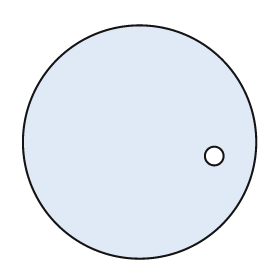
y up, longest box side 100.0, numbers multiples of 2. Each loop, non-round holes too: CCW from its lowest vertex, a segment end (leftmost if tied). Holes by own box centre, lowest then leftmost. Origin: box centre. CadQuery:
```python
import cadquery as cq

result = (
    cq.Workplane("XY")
    .moveTo(0.0, 0.0)
    .circle(50.0)
    .moveTo(32.0, -6.0)
    .circle(4.0)
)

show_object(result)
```